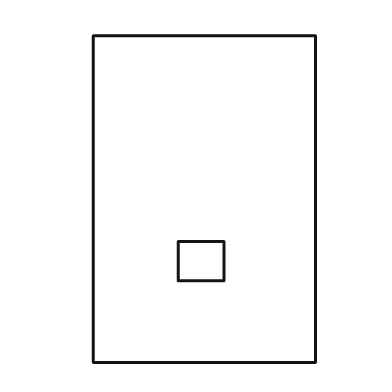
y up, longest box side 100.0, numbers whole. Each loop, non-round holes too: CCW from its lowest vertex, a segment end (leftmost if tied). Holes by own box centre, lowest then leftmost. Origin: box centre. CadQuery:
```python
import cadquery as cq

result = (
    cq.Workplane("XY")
    .moveTo(-34.0, -50.0)
    .lineTo(34.0, -50.0)
    .lineTo(34.0, 50.0)
    .lineTo(-34.0, 50.0)
    .close()
    .moveTo(-8.0, -25.0)
    .lineTo(6.0, -25.0)
    .lineTo(6.0, -13.0)
    .lineTo(-8.0, -13.0)
    .close()
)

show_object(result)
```